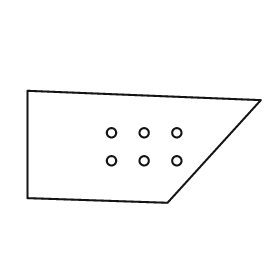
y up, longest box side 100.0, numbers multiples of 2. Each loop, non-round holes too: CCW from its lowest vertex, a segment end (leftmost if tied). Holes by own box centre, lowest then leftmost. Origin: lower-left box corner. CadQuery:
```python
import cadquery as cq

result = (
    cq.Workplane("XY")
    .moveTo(60.0, 0.0)
    .lineTo(100.0, 44.0)
    .lineTo(0.0, 48.0)
    .lineTo(0.0, 2.0)
    .close()
    .moveTo(36.0, 18.0)
    .circle(2.0)
    .moveTo(50.0, 18.0)
    .circle(2.0)
    .moveTo(64.0, 18.0)
    .circle(2.0)
    .moveTo(36.0, 30.0)
    .circle(2.0)
    .moveTo(50.0, 30.0)
    .circle(2.0)
    .moveTo(64.0, 30.0)
    .circle(2.0)
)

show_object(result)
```